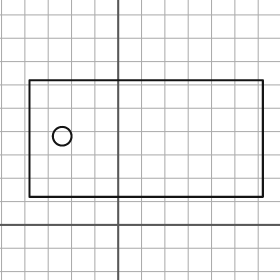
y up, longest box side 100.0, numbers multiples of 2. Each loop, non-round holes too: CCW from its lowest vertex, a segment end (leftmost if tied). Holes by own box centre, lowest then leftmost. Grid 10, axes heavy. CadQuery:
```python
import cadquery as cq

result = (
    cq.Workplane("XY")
    .moveTo(-38.0, 12.0)
    .lineTo(62.0, 12.0)
    .lineTo(62.0, 62.0)
    .lineTo(-38.0, 62.0)
    .close()
    .moveTo(-24.0, 38.0)
    .circle(4.0)
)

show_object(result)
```